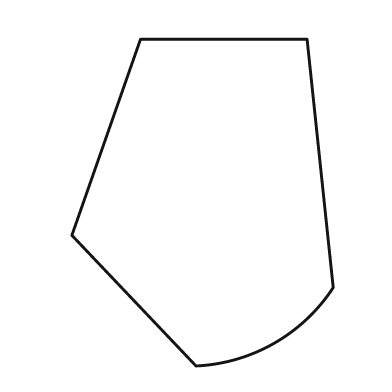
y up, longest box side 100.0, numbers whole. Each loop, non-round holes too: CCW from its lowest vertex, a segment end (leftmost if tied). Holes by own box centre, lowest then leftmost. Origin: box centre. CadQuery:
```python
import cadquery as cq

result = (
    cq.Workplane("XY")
    .moveTo(-2.0, -50.0)
    .threePointArc((22.0, -43.0), (40.0, -26.0))
    .lineTo(32.0, 50.0)
    .lineTo(-19.0, 50.0)
    .lineTo(-40.0, -10.0)
    .close()
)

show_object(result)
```